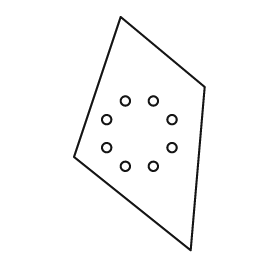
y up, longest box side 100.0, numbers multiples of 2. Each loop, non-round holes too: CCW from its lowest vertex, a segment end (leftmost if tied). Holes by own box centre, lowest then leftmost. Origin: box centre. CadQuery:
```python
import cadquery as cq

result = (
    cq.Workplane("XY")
    .moveTo(22.0, -50.0)
    .lineTo(28.0, 20.0)
    .lineTo(-8.0, 50.0)
    .lineTo(-28.0, -10.0)
    .close()
    .moveTo(-6.0, -14.0)
    .circle(2.0)
    .moveTo(6.0, -14.0)
    .circle(2.0)
    .moveTo(-14.0, -6.0)
    .circle(2.0)
    .moveTo(14.0, -6.0)
    .circle(2.0)
    .moveTo(-14.0, 6.0)
    .circle(2.0)
    .moveTo(14.0, 6.0)
    .circle(2.0)
    .moveTo(-6.0, 14.0)
    .circle(2.0)
    .moveTo(6.0, 14.0)
    .circle(2.0)
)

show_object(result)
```